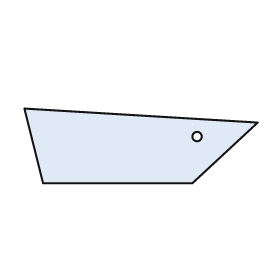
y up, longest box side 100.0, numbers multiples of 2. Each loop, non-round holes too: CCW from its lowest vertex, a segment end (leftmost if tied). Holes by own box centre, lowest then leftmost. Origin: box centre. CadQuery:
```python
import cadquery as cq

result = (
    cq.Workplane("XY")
    .moveTo(-42.0, -16.0)
    .lineTo(22.0, -16.0)
    .lineTo(50.0, 10.0)
    .lineTo(-50.0, 16.0)
    .close()
    .moveTo(24.0, 4.0)
    .circle(2.0)
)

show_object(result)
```